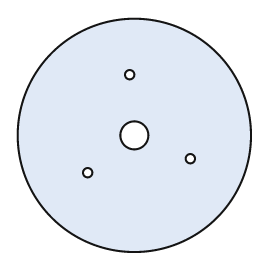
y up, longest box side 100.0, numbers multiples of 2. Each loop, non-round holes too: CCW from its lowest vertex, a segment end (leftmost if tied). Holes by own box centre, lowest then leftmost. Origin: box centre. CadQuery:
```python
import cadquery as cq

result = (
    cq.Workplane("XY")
    .moveTo(0.0, 0.0)
    .circle(50.0)
    .moveTo(-20.0, -16.0)
    .circle(2.0)
    .moveTo(24.0, -10.0)
    .circle(2.0)
    .moveTo(0.0, 0.0)
    .circle(6.0)
    .moveTo(-2.0, 26.0)
    .circle(2.0)
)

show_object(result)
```